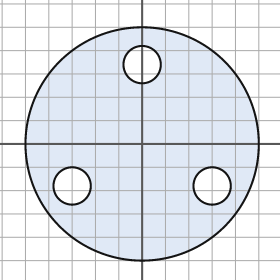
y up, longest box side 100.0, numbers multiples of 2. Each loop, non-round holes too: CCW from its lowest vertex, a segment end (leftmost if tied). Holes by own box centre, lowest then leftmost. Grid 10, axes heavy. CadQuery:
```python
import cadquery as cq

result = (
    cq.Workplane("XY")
    .moveTo(0.0, 0.0)
    .circle(50.0)
    .moveTo(-30.0, -18.0)
    .circle(8.0)
    .moveTo(30.0, -18.0)
    .circle(8.0)
    .moveTo(0.0, 34.0)
    .circle(8.0)
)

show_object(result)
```